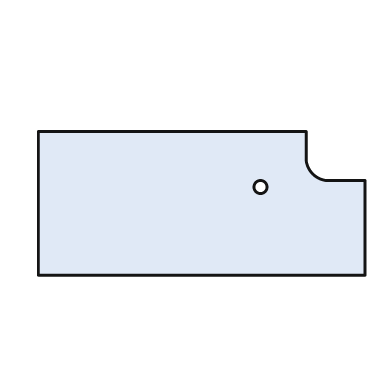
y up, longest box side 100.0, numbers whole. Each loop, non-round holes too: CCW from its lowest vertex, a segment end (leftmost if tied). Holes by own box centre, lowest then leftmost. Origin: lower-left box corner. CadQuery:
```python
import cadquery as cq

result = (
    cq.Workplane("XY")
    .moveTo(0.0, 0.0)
    .lineTo(100.0, 0.0)
    .lineTo(100.0, 29.0)
    .lineTo(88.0, 29.0)
    .threePointArc((84.0, 31.0), (82.0, 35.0))
    .lineTo(82.0, 44.0)
    .lineTo(0.0, 44.0)
    .close()
    .moveTo(68.0, 27.0)
    .circle(2.0)
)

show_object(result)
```